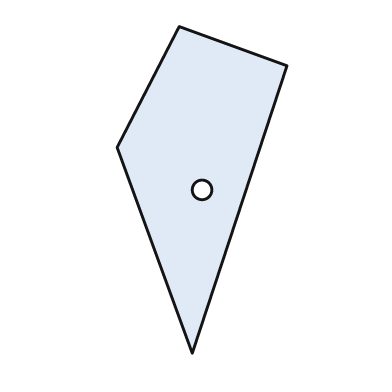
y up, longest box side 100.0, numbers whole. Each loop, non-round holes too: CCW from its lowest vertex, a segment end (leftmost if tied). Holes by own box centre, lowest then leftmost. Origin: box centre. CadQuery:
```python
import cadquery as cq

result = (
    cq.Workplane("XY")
    .moveTo(-3.0, -50.0)
    .lineTo(26.0, 38.0)
    .lineTo(-7.0, 50.0)
    .lineTo(-26.0, 13.0)
    .close()
    .moveTo(0.0, 0.0)
    .circle(3.0)
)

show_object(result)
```